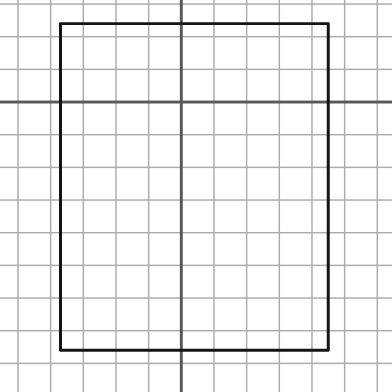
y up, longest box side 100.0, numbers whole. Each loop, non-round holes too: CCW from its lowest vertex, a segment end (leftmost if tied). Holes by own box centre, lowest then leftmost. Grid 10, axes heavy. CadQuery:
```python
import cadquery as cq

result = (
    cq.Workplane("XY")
    .moveTo(-37.0, -76.0)
    .lineTo(45.0, -76.0)
    .lineTo(45.0, 24.0)
    .lineTo(-37.0, 24.0)
    .close()
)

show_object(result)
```